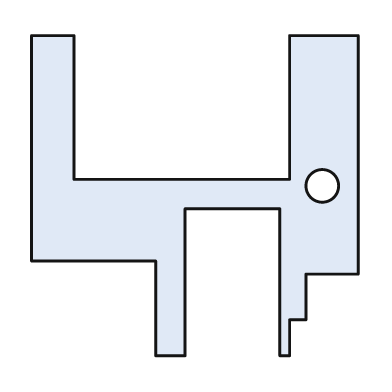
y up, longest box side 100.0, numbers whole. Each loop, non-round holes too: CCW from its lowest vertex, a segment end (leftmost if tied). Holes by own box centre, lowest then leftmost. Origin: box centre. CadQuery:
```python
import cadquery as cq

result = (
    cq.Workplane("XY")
    .moveTo(-12.0, -49.0)
    .lineTo(-3.0, -49.0)
    .lineTo(-3.0, -4.0)
    .lineTo(26.0, -4.0)
    .lineTo(26.0, -49.0)
    .lineTo(29.0, -49.0)
    .lineTo(29.0, -38.0)
    .lineTo(34.0, -38.0)
    .lineTo(34.0, -24.0)
    .lineTo(50.0, -24.0)
    .lineTo(50.0, 49.0)
    .lineTo(29.0, 49.0)
    .lineTo(29.0, 5.0)
    .lineTo(-37.0, 5.0)
    .lineTo(-37.0, 49.0)
    .lineTo(-50.0, 49.0)
    .lineTo(-50.0, -20.0)
    .lineTo(-12.0, -20.0)
    .close()
    .moveTo(39.0, 3.0)
    .circle(5.0)
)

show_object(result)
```